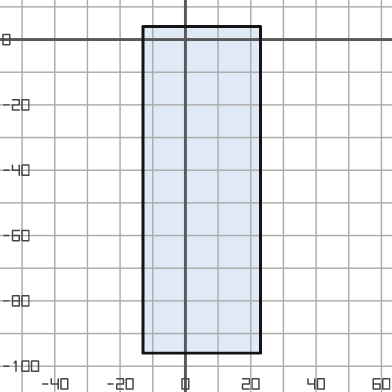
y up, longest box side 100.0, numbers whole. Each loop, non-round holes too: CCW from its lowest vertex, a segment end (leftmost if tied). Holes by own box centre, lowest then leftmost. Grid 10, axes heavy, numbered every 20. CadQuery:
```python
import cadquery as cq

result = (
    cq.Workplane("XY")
    .moveTo(-13.0, -96.0)
    .lineTo(23.0, -96.0)
    .lineTo(23.0, 4.0)
    .lineTo(-13.0, 4.0)
    .close()
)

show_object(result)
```